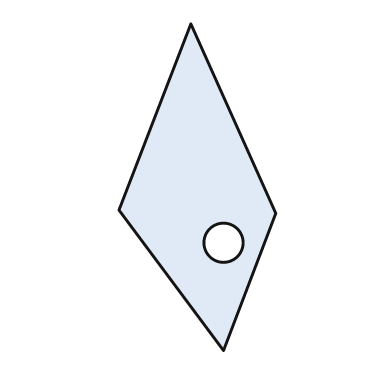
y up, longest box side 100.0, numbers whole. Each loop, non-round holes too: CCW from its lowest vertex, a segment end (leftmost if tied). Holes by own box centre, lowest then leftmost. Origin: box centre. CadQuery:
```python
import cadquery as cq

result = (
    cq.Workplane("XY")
    .moveTo(8.0, -50.0)
    .lineTo(24.0, -8.0)
    .lineTo(-2.0, 50.0)
    .lineTo(-24.0, -7.0)
    .close()
    .moveTo(8.0, -17.0)
    .circle(6.0)
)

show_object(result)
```